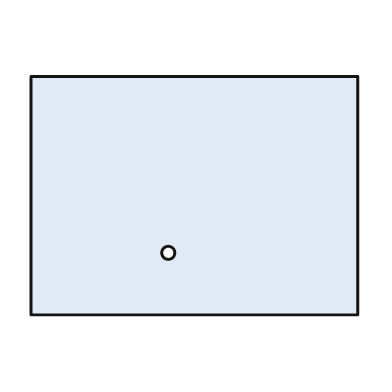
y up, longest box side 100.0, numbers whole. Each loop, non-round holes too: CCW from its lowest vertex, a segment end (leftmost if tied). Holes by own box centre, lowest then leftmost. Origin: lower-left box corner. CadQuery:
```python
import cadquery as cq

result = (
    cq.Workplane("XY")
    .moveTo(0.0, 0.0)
    .lineTo(100.0, 0.0)
    .lineTo(100.0, 73.0)
    .lineTo(0.0, 73.0)
    .close()
    .moveTo(42.0, 19.0)
    .circle(2.0)
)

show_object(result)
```